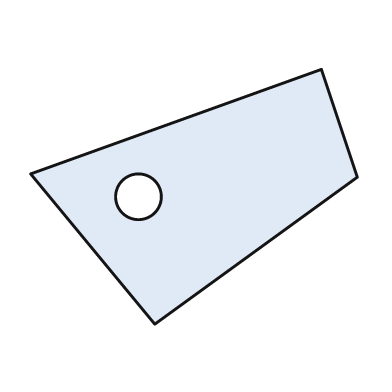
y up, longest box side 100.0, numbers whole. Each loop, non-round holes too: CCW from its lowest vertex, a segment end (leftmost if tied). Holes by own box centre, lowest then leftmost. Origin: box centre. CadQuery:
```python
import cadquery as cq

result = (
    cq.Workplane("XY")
    .moveTo(-12.0, -39.0)
    .lineTo(50.0, 6.0)
    .lineTo(39.0, 39.0)
    .lineTo(-50.0, 7.0)
    .close()
    .moveTo(-17.0, 0.0)
    .circle(7.0)
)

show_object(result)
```